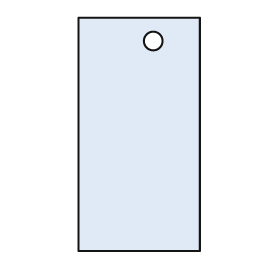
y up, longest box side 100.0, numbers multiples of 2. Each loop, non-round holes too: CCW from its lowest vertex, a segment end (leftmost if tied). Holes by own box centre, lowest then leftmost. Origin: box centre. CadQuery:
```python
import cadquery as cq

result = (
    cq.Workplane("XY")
    .moveTo(-26.0, -50.0)
    .lineTo(26.0, -50.0)
    .lineTo(26.0, 50.0)
    .lineTo(-26.0, 50.0)
    .close()
    .moveTo(6.0, 40.0)
    .circle(4.0)
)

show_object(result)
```